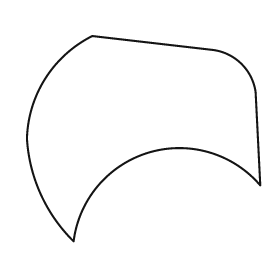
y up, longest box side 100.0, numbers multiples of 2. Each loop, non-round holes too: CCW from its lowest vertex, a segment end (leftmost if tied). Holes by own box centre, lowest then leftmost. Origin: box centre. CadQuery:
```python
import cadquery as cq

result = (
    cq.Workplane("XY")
    .moveTo(-30.0, -44.0)
    .threePointArc((2.0, -6.0), (50.0, -20.0))
    .lineTo(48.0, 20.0)
    .threePointArc((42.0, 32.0), (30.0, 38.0))
    .lineTo(-22.0, 44.0)
    .threePointArc((-42.0, 26.0), (-50.0, 0.0))
    .threePointArc((-44.0, -24.0), (-30.0, -44.0))
    .close()
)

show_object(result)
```